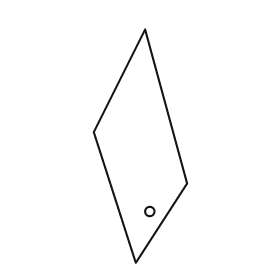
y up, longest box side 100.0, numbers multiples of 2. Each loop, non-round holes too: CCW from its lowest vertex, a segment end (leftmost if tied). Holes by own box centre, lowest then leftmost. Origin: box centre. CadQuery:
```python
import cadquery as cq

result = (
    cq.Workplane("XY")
    .moveTo(-2.0, -50.0)
    .lineTo(20.0, -16.0)
    .lineTo(2.0, 50.0)
    .lineTo(-20.0, 6.0)
    .close()
    .moveTo(4.0, -28.0)
    .circle(2.0)
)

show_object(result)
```